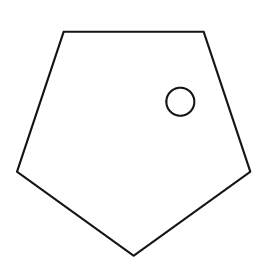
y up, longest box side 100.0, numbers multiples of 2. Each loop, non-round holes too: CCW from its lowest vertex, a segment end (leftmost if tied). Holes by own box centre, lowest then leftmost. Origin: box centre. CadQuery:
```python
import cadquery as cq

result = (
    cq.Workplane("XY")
    .moveTo(0.0, -48.0)
    .lineTo(50.0, -12.0)
    .lineTo(30.0, 48.0)
    .lineTo(-30.0, 48.0)
    .lineTo(-50.0, -12.0)
    .close()
    .moveTo(20.0, 18.0)
    .circle(6.0)
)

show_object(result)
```